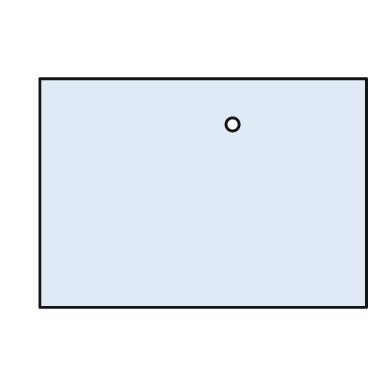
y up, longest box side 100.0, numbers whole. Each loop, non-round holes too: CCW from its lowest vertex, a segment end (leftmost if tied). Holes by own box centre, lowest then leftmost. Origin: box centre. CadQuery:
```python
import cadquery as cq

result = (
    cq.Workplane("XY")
    .moveTo(-50.0, -35.0)
    .lineTo(50.0, -35.0)
    .lineTo(50.0, 35.0)
    .lineTo(-50.0, 35.0)
    .close()
    .moveTo(9.0, 21.0)
    .circle(2.0)
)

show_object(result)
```